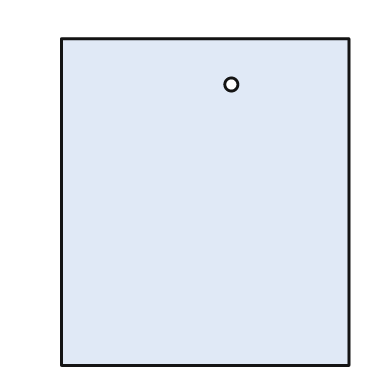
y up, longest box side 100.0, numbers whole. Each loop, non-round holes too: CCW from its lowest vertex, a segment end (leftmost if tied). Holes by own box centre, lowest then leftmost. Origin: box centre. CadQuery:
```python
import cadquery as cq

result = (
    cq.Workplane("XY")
    .moveTo(-44.0, -50.0)
    .lineTo(44.0, -50.0)
    .lineTo(44.0, 50.0)
    .lineTo(-44.0, 50.0)
    .close()
    .moveTo(8.0, 36.0)
    .circle(2.0)
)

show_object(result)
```